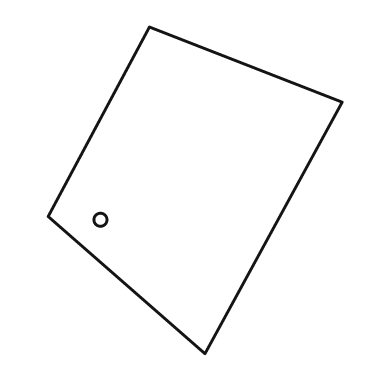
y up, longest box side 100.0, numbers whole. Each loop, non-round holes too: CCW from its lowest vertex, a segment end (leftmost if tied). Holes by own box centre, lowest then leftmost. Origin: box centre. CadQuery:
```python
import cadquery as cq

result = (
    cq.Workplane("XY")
    .moveTo(3.0, -50.0)
    .lineTo(45.0, 27.0)
    .lineTo(-14.0, 50.0)
    .lineTo(-45.0, -8.0)
    .close()
    .moveTo(-29.0, -9.0)
    .circle(2.0)
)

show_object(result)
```